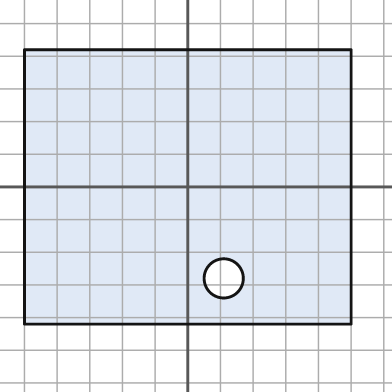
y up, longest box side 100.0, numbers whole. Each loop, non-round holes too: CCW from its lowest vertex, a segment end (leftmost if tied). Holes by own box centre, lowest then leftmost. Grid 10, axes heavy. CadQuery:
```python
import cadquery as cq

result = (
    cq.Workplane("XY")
    .moveTo(-50.0, -42.0)
    .lineTo(50.0, -42.0)
    .lineTo(50.0, 42.0)
    .lineTo(-50.0, 42.0)
    .close()
    .moveTo(11.0, -28.0)
    .circle(6.0)
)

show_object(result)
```